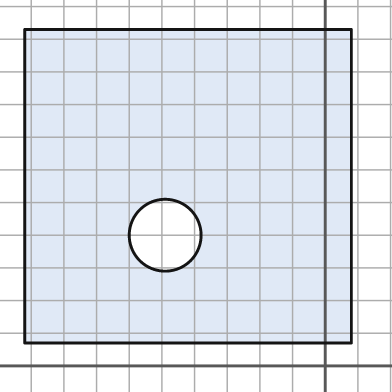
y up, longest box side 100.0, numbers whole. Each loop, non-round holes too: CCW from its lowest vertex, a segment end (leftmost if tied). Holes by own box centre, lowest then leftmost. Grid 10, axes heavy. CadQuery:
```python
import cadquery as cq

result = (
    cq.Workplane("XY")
    .moveTo(-92.0, 7.0)
    .lineTo(8.0, 7.0)
    .lineTo(8.0, 103.0)
    .lineTo(-92.0, 103.0)
    .close()
    .moveTo(-49.0, 40.0)
    .circle(11.0)
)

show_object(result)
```